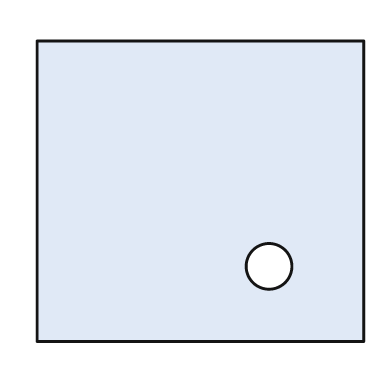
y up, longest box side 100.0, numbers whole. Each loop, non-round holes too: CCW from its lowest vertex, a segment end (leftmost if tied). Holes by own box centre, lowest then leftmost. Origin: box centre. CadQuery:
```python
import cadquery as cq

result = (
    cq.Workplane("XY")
    .moveTo(-50.0, -46.0)
    .lineTo(50.0, -46.0)
    .lineTo(50.0, 46.0)
    .lineTo(-50.0, 46.0)
    .close()
    .moveTo(21.0, -23.0)
    .circle(7.0)
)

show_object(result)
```